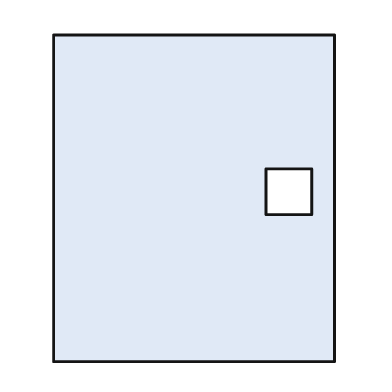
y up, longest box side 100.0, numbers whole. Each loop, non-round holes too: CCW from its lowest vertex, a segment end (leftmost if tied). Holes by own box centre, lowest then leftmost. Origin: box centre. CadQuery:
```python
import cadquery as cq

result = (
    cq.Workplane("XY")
    .moveTo(-43.0, -50.0)
    .lineTo(43.0, -50.0)
    .lineTo(43.0, 50.0)
    .lineTo(-43.0, 50.0)
    .close()
    .moveTo(22.0, -5.0)
    .lineTo(36.0, -5.0)
    .lineTo(36.0, 9.0)
    .lineTo(22.0, 9.0)
    .close()
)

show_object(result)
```